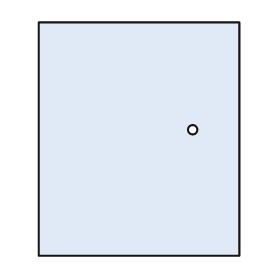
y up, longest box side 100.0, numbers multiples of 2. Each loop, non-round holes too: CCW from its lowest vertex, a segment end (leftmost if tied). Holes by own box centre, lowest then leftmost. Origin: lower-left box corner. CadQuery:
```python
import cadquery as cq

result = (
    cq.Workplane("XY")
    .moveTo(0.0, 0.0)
    .lineTo(86.0, 0.0)
    .lineTo(86.0, 100.0)
    .lineTo(0.0, 100.0)
    .close()
    .moveTo(66.0, 54.0)
    .circle(2.0)
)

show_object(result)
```